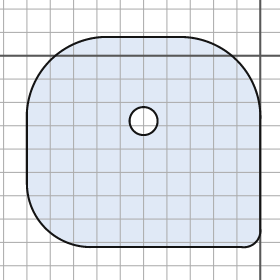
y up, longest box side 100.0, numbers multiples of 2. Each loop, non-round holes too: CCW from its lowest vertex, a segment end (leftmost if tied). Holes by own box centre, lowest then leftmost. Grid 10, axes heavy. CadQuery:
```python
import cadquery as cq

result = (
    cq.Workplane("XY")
    .moveTo(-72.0, -82.0)
    .lineTo(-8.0, -82.0)
    .threePointArc((-2.0, -80.0), (0.0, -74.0))
    .lineTo(0.0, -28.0)
    .threePointArc((-10.0, -2.0), (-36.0, 8.0))
    .lineTo(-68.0, 8.0)
    .threePointArc((-90.0, -2.0), (-100.0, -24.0))
    .lineTo(-100.0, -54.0)
    .threePointArc((-92.0, -74.0), (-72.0, -82.0))
    .close()
    .moveTo(-50.0, -28.0)
    .circle(6.0)
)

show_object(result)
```